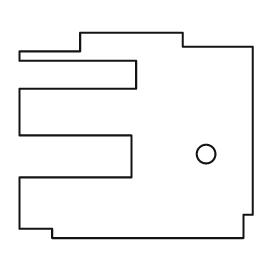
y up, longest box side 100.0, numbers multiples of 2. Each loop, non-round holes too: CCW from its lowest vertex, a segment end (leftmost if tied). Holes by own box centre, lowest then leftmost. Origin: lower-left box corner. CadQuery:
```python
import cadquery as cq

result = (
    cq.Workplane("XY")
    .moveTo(14.0, 0.0)
    .lineTo(96.0, 0.0)
    .lineTo(96.0, 10.0)
    .lineTo(100.0, 10.0)
    .lineTo(100.0, 82.0)
    .lineTo(70.0, 82.0)
    .lineTo(70.0, 88.0)
    .lineTo(26.0, 88.0)
    .lineTo(26.0, 80.0)
    .lineTo(0.0, 80.0)
    .lineTo(0.0, 76.0)
    .lineTo(50.0, 76.0)
    .lineTo(50.0, 64.0)
    .lineTo(0.0, 64.0)
    .lineTo(0.0, 44.0)
    .lineTo(48.0, 44.0)
    .lineTo(48.0, 26.0)
    .lineTo(0.0, 26.0)
    .lineTo(0.0, 4.0)
    .lineTo(14.0, 4.0)
    .close()
    .moveTo(80.0, 36.0)
    .circle(4.0)
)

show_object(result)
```